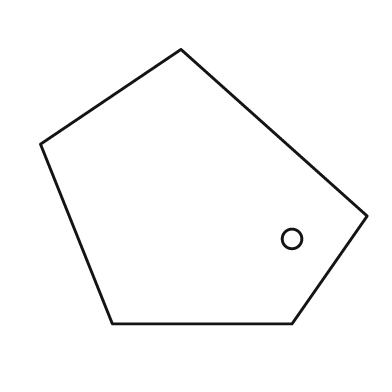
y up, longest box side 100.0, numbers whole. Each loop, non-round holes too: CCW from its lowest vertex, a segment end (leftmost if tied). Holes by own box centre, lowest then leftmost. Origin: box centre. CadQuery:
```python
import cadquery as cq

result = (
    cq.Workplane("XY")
    .moveTo(-28.0, -42.0)
    .lineTo(27.0, -42.0)
    .lineTo(50.0, -9.0)
    .lineTo(-7.0, 42.0)
    .lineTo(-50.0, 13.0)
    .close()
    .moveTo(27.0, -16.0)
    .circle(3.0)
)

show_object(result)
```